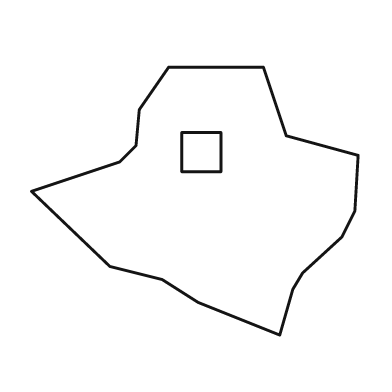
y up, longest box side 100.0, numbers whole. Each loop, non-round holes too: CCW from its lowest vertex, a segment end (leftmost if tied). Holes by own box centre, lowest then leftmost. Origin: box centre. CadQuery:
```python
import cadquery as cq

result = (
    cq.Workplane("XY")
    .moveTo(26.0, -41.0)
    .lineTo(30.0, -27.0)
    .lineTo(33.0, -22.0)
    .lineTo(45.0, -11.0)
    .lineTo(49.0, -3.0)
    .lineTo(50.0, 14.0)
    .lineTo(28.0, 20.0)
    .lineTo(21.0, 41.0)
    .lineTo(-8.0, 41.0)
    .lineTo(-17.0, 28.0)
    .lineTo(-18.0, 17.0)
    .lineTo(-23.0, 12.0)
    .lineTo(-50.0, 3.0)
    .lineTo(-26.0, -20.0)
    .lineTo(-10.0, -24.0)
    .lineTo(1.0, -31.0)
    .close()
    .moveTo(-4.0, 9.0)
    .lineTo(8.0, 9.0)
    .lineTo(8.0, 21.0)
    .lineTo(-4.0, 21.0)
    .close()
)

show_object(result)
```